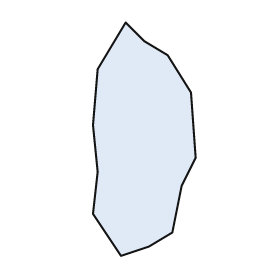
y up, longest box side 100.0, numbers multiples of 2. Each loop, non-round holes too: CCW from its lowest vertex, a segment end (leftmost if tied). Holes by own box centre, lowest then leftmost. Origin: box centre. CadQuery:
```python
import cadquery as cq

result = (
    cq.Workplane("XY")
    .moveTo(-10.0, -50.0)
    .lineTo(2.0, -46.0)
    .lineTo(12.0, -40.0)
    .lineTo(16.0, -20.0)
    .lineTo(22.0, -8.0)
    .lineTo(20.0, 20.0)
    .lineTo(10.0, 36.0)
    .lineTo(0.0, 42.0)
    .lineTo(-8.0, 50.0)
    .lineTo(-20.0, 30.0)
    .lineTo(-22.0, 6.0)
    .lineTo(-20.0, -14.0)
    .lineTo(-22.0, -32.0)
    .close()
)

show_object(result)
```